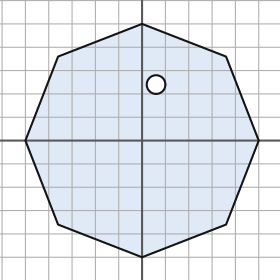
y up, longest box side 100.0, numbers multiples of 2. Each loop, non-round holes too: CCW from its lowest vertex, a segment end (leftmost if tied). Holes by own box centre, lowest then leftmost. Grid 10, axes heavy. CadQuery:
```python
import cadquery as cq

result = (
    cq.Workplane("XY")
    .moveTo(0.0, -50.0)
    .lineTo(36.0, -36.0)
    .lineTo(50.0, 0.0)
    .lineTo(36.0, 36.0)
    .lineTo(0.0, 50.0)
    .lineTo(-36.0, 36.0)
    .lineTo(-50.0, 0.0)
    .lineTo(-36.0, -36.0)
    .close()
    .moveTo(6.0, 24.0)
    .circle(4.0)
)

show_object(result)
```